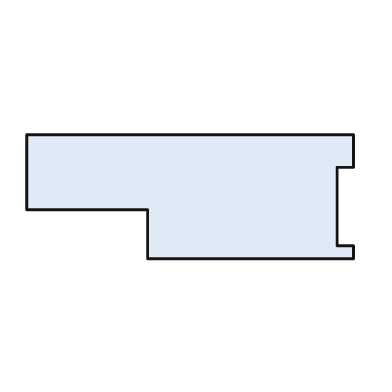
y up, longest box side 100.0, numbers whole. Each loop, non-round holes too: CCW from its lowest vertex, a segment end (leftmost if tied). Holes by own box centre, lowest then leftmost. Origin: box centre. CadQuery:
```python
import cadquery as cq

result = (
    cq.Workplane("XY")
    .moveTo(-13.0, -19.0)
    .lineTo(50.0, -19.0)
    .lineTo(50.0, -15.0)
    .lineTo(45.0, -15.0)
    .lineTo(45.0, 9.0)
    .lineTo(50.0, 9.0)
    .lineTo(50.0, 19.0)
    .lineTo(-50.0, 19.0)
    .lineTo(-50.0, -4.0)
    .lineTo(-13.0, -4.0)
    .close()
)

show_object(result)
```